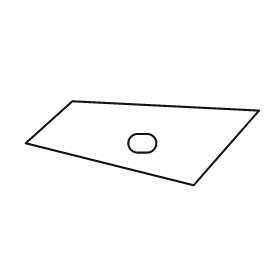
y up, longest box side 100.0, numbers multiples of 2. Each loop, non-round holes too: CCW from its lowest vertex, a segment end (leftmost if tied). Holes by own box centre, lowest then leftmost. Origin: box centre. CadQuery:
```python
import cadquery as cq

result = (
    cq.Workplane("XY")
    .moveTo(22.0, -18.0)
    .lineTo(50.0, 14.0)
    .lineTo(-30.0, 18.0)
    .lineTo(-50.0, 0.0)
    .close()
    .moveTo(-2.0, -4.0)
    .lineTo(2.0, -4.0)
    .threePointArc((6.0, 0.0), (2.0, 4.0))
    .lineTo(-2.0, 4.0)
    .threePointArc((-6.0, 0.0), (-2.0, -4.0))
    .close()
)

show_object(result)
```